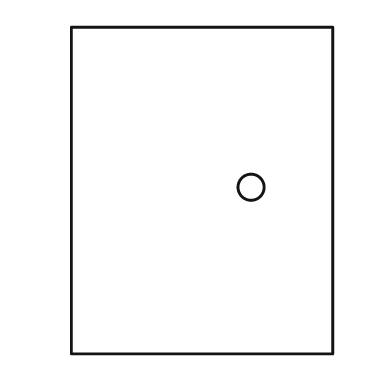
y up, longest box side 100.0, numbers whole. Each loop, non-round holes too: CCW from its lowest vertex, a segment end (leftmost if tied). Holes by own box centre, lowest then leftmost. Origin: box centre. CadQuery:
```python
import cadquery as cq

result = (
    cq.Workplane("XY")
    .moveTo(-40.0, -50.0)
    .lineTo(40.0, -50.0)
    .lineTo(40.0, 50.0)
    .lineTo(-40.0, 50.0)
    .close()
    .moveTo(15.0, 1.0)
    .circle(4.0)
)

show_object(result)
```